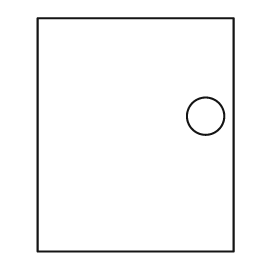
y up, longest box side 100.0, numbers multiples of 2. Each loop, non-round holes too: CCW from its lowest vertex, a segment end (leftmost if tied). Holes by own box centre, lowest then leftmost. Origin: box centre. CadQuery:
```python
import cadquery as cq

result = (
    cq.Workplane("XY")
    .moveTo(-42.0, -50.0)
    .lineTo(42.0, -50.0)
    .lineTo(42.0, 50.0)
    .lineTo(-42.0, 50.0)
    .close()
    .moveTo(30.0, 8.0)
    .circle(8.0)
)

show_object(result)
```